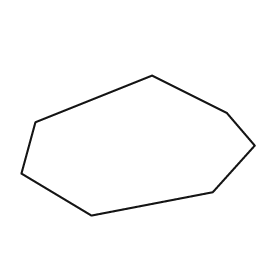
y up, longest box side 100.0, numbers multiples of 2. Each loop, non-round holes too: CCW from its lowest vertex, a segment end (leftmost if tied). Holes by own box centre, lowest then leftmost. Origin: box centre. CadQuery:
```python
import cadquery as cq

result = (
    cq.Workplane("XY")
    .moveTo(-20.0, -30.0)
    .lineTo(32.0, -20.0)
    .lineTo(50.0, 0.0)
    .lineTo(38.0, 14.0)
    .lineTo(6.0, 30.0)
    .lineTo(-44.0, 10.0)
    .lineTo(-50.0, -12.0)
    .close()
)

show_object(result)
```